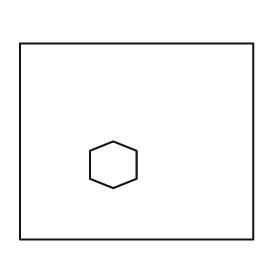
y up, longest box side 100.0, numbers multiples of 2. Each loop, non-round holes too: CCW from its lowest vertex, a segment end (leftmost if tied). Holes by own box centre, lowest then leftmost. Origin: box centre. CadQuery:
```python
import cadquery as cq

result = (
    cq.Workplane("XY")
    .moveTo(-50.0, -42.0)
    .lineTo(50.0, -42.0)
    .lineTo(50.0, 42.0)
    .lineTo(-50.0, 42.0)
    .close()
    .moveTo(-10.0, -20.0)
    .lineTo(0.0, -16.0)
    .lineTo(0.0, -4.0)
    .lineTo(-10.0, 0.0)
    .lineTo(-20.0, -4.0)
    .lineTo(-20.0, -16.0)
    .close()
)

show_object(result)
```